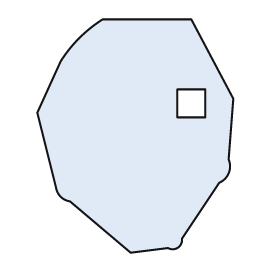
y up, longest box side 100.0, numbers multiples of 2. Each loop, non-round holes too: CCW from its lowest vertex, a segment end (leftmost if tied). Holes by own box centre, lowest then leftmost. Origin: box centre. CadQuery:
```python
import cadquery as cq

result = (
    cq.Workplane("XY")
    .moveTo(-2.0, -50.0)
    .lineTo(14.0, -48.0)
    .threePointArc((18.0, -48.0), (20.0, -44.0))
    .lineTo(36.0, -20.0)
    .threePointArc((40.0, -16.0), (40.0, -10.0))
    .lineTo(42.0, 16.0)
    .lineTo(24.0, 50.0)
    .lineTo(-14.0, 50.0)
    .threePointArc((-24.0, 42.0), (-32.0, 32.0))
    .lineTo(-42.0, 10.0)
    .lineTo(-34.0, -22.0)
    .threePointArc((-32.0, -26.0), (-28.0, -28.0))
    .close()
    .moveTo(18.0, 8.0)
    .lineTo(30.0, 8.0)
    .lineTo(30.0, 20.0)
    .lineTo(18.0, 20.0)
    .close()
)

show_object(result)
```